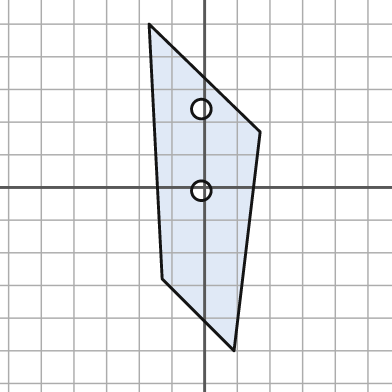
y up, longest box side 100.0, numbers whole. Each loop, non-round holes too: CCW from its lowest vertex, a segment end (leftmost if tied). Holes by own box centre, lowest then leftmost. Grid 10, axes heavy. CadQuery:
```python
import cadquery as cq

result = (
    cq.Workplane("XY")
    .moveTo(9.0, -50.0)
    .lineTo(17.0, 17.0)
    .lineTo(-17.0, 50.0)
    .lineTo(-13.0, -28.0)
    .close()
    .moveTo(-1.0, -1.0)
    .circle(3.0)
    .moveTo(-1.0, 24.0)
    .circle(3.0)
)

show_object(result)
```